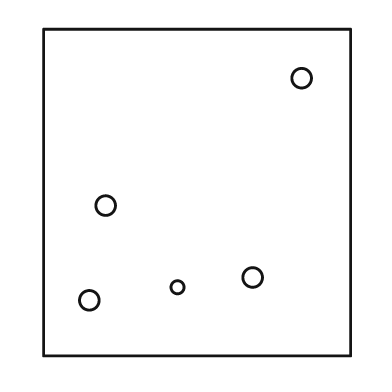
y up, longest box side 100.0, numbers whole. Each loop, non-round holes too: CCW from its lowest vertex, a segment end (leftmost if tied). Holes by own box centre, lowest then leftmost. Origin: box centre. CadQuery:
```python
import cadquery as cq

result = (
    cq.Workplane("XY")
    .moveTo(-47.0, -50.0)
    .lineTo(47.0, -50.0)
    .lineTo(47.0, 50.0)
    .lineTo(-47.0, 50.0)
    .close()
    .moveTo(-33.0, -33.0)
    .circle(3.0)
    .moveTo(-6.0, -29.0)
    .circle(2.0)
    .moveTo(17.0, -26.0)
    .circle(3.0)
    .moveTo(-28.0, -4.0)
    .circle(3.0)
    .moveTo(32.0, 35.0)
    .circle(3.0)
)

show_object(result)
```